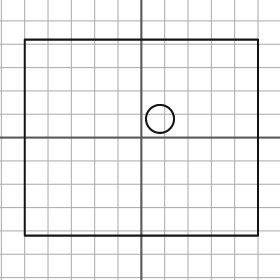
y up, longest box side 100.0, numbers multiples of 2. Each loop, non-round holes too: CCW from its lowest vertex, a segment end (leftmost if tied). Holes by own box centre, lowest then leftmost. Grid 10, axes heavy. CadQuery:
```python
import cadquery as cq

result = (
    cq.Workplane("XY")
    .moveTo(-50.0, -42.0)
    .lineTo(50.0, -42.0)
    .lineTo(50.0, 42.0)
    .lineTo(-50.0, 42.0)
    .close()
    .moveTo(8.0, 8.0)
    .circle(6.0)
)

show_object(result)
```